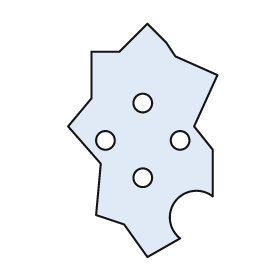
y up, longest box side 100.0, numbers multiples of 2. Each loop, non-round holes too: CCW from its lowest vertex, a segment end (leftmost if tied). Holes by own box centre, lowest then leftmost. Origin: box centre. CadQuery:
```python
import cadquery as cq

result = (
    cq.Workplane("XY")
    .moveTo(2.0, -50.0)
    .lineTo(16.0, -42.0)
    .threePointArc((14.0, -26.0), (30.0, -24.0))
    .lineTo(30.0, -4.0)
    .lineTo(22.0, 6.0)
    .lineTo(32.0, 28.0)
    .lineTo(14.0, 36.0)
    .lineTo(10.0, 42.0)
    .lineTo(2.0, 50.0)
    .lineTo(-10.0, 38.0)
    .lineTo(-22.0, 38.0)
    .lineTo(-22.0, 18.0)
    .lineTo(-32.0, 6.0)
    .lineTo(-18.0, -10.0)
    .lineTo(-20.0, -32.0)
    .lineTo(-8.0, -36.0)
    .close()
    .moveTo(0.0, -16.0)
    .circle(4.0)
    .moveTo(-16.0, 0.0)
    .circle(4.0)
    .moveTo(16.0, 0.0)
    .circle(4.0)
    .moveTo(0.0, 16.0)
    .circle(4.0)
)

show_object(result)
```